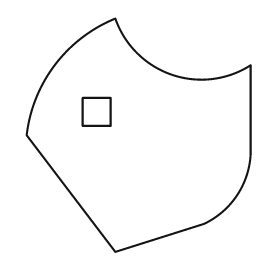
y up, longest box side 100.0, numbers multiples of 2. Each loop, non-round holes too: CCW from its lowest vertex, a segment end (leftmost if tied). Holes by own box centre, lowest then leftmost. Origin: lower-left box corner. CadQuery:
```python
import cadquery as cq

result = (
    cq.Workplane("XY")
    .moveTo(38.0, 0.0)
    .lineTo(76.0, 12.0)
    .threePointArc((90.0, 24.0), (96.0, 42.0))
    .lineTo(96.0, 80.0)
    .threePointArc((62.0, 76.0), (38.0, 100.0))
    .threePointArc((12.0, 80.0), (0.0, 50.0))
    .close()
    .moveTo(24.0, 54.0)
    .lineTo(36.0, 54.0)
    .lineTo(36.0, 66.0)
    .lineTo(24.0, 66.0)
    .close()
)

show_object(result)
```